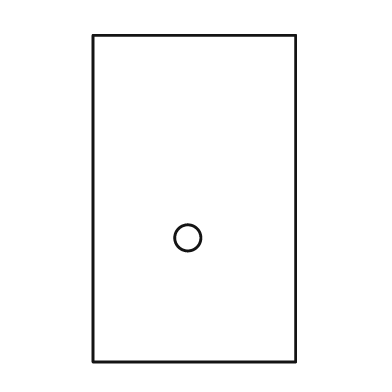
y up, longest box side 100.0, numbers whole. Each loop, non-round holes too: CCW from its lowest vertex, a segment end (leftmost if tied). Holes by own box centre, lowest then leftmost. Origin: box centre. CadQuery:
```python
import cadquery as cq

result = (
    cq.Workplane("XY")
    .moveTo(-31.0, -50.0)
    .lineTo(31.0, -50.0)
    .lineTo(31.0, 50.0)
    .lineTo(-31.0, 50.0)
    .close()
    .moveTo(-2.0, -12.0)
    .circle(4.0)
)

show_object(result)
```